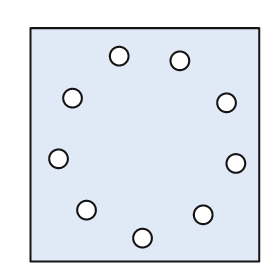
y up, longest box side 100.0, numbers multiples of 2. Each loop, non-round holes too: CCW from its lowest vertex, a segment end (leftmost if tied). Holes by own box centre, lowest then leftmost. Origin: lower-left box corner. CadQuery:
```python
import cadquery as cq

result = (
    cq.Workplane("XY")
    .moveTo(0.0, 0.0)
    .lineTo(98.0, 0.0)
    .lineTo(98.0, 100.0)
    .lineTo(0.0, 100.0)
    .close()
    .moveTo(48.0, 10.0)
    .circle(4.0)
    .moveTo(74.0, 20.0)
    .circle(4.0)
    .moveTo(24.0, 22.0)
    .circle(4.0)
    .moveTo(88.0, 42.0)
    .circle(4.0)
    .moveTo(12.0, 44.0)
    .circle(4.0)
    .moveTo(84.0, 68.0)
    .circle(4.0)
    .moveTo(18.0, 70.0)
    .circle(4.0)
    .moveTo(64.0, 86.0)
    .circle(4.0)
    .moveTo(38.0, 88.0)
    .circle(4.0)
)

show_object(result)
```